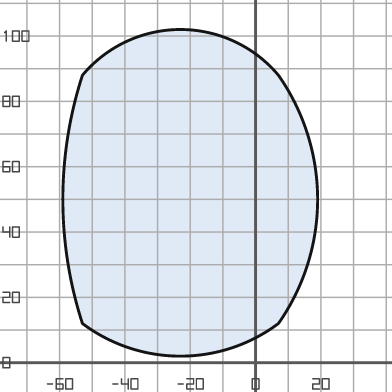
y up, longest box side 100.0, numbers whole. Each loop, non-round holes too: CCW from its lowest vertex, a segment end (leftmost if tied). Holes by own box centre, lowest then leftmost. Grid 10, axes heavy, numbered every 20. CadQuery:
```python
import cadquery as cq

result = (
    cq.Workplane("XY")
    .moveTo(-53.0, 12.0)
    .threePointArc((-23.0, 2.0), (7.0, 12.0))
    .threePointArc((19.0, 50.0), (7.0, 88.0))
    .threePointArc((-23.0, 102.0), (-53.0, 88.0))
    .threePointArc((-59.0, 50.0), (-53.0, 12.0))
    .close()
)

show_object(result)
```